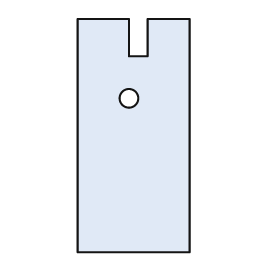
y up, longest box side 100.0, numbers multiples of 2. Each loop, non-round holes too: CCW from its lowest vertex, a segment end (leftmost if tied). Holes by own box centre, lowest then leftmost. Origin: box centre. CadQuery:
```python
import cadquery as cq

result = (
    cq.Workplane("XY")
    .moveTo(-24.0, -50.0)
    .lineTo(24.0, -50.0)
    .lineTo(24.0, 50.0)
    .lineTo(6.0, 50.0)
    .lineTo(6.0, 34.0)
    .lineTo(-2.0, 34.0)
    .lineTo(-2.0, 50.0)
    .lineTo(-24.0, 50.0)
    .close()
    .moveTo(-2.0, 16.0)
    .circle(4.0)
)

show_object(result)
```